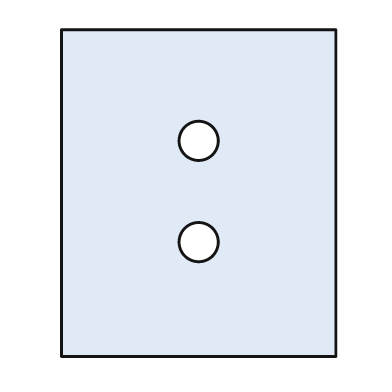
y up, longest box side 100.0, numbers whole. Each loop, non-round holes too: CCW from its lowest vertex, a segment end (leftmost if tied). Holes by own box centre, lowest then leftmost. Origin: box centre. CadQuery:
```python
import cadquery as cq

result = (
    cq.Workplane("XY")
    .moveTo(-42.0, -50.0)
    .lineTo(42.0, -50.0)
    .lineTo(42.0, 50.0)
    .lineTo(-42.0, 50.0)
    .close()
    .moveTo(0.0, -15.0)
    .circle(6.0)
    .moveTo(0.0, 16.0)
    .circle(6.0)
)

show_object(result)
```